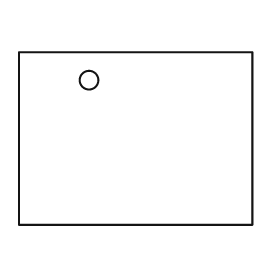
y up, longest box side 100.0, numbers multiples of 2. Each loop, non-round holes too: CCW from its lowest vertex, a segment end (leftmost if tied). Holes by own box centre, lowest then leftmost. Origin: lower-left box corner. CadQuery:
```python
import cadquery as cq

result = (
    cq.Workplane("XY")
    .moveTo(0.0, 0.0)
    .lineTo(100.0, 0.0)
    .lineTo(100.0, 74.0)
    .lineTo(0.0, 74.0)
    .close()
    .moveTo(30.0, 62.0)
    .circle(4.0)
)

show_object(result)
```